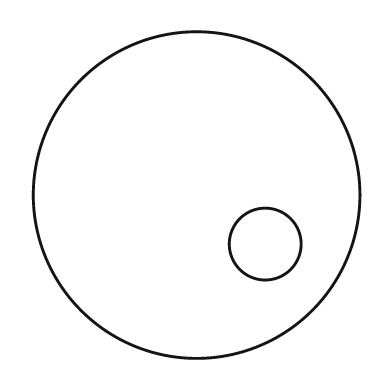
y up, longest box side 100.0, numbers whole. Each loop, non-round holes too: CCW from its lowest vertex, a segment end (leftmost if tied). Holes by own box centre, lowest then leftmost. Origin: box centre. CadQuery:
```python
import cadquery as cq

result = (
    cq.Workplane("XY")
    .moveTo(0.0, 0.0)
    .circle(50.0)
    .moveTo(21.0, -15.0)
    .circle(11.0)
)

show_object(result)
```